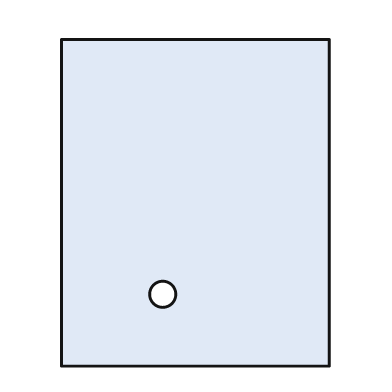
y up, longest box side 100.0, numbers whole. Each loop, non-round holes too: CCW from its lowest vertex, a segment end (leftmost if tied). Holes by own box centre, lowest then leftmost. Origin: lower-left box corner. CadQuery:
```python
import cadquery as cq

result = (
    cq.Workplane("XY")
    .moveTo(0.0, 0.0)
    .lineTo(82.0, 0.0)
    .lineTo(82.0, 100.0)
    .lineTo(0.0, 100.0)
    .close()
    .moveTo(31.0, 22.0)
    .circle(4.0)
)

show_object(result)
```